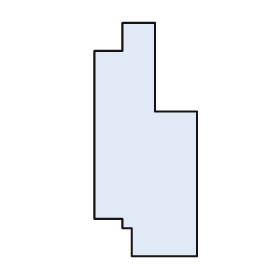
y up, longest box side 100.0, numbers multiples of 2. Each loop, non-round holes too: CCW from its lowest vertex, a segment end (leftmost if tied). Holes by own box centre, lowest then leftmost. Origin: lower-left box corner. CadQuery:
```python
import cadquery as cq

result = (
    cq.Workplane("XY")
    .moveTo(16.0, 0.0)
    .lineTo(44.0, 0.0)
    .lineTo(44.0, 62.0)
    .lineTo(26.0, 62.0)
    .lineTo(26.0, 100.0)
    .lineTo(12.0, 100.0)
    .lineTo(12.0, 88.0)
    .lineTo(0.0, 88.0)
    .lineTo(0.0, 16.0)
    .lineTo(12.0, 16.0)
    .lineTo(12.0, 12.0)
    .lineTo(16.0, 12.0)
    .close()
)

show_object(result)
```